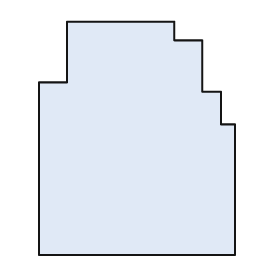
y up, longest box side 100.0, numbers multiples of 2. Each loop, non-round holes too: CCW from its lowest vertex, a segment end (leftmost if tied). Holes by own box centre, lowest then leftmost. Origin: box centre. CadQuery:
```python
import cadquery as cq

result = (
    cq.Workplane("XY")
    .moveTo(-42.0, -50.0)
    .lineTo(42.0, -50.0)
    .lineTo(42.0, 6.0)
    .lineTo(36.0, 6.0)
    .lineTo(36.0, 20.0)
    .lineTo(28.0, 20.0)
    .lineTo(28.0, 42.0)
    .lineTo(16.0, 42.0)
    .lineTo(16.0, 50.0)
    .lineTo(-30.0, 50.0)
    .lineTo(-30.0, 24.0)
    .lineTo(-42.0, 24.0)
    .close()
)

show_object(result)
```